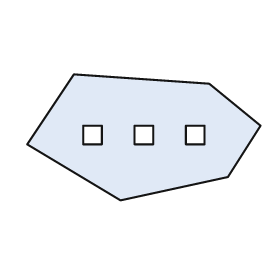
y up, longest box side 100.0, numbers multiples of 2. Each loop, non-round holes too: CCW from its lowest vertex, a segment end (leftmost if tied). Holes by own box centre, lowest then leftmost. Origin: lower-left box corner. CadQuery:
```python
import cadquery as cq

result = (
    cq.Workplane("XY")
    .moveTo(40.0, 0.0)
    .lineTo(86.0, 10.0)
    .lineTo(100.0, 32.0)
    .lineTo(78.0, 50.0)
    .lineTo(20.0, 54.0)
    .lineTo(0.0, 24.0)
    .close()
    .moveTo(24.0, 24.0)
    .lineTo(32.0, 24.0)
    .lineTo(32.0, 32.0)
    .lineTo(24.0, 32.0)
    .close()
    .moveTo(46.0, 24.0)
    .lineTo(54.0, 24.0)
    .lineTo(54.0, 32.0)
    .lineTo(46.0, 32.0)
    .close()
    .moveTo(68.0, 24.0)
    .lineTo(76.0, 24.0)
    .lineTo(76.0, 32.0)
    .lineTo(68.0, 32.0)
    .close()
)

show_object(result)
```